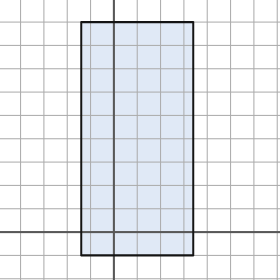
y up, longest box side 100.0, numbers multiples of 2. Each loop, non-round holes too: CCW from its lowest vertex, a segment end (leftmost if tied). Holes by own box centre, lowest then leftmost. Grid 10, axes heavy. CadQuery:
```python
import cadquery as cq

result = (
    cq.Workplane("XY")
    .moveTo(-14.0, -10.0)
    .lineTo(34.0, -10.0)
    .lineTo(34.0, 90.0)
    .lineTo(-14.0, 90.0)
    .close()
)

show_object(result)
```